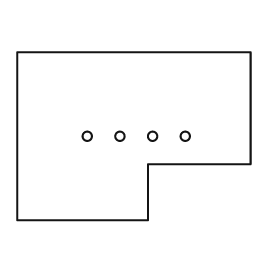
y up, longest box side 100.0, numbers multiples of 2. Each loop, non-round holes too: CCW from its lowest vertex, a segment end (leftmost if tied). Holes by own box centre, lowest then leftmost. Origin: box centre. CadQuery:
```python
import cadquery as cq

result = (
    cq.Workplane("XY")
    .moveTo(-50.0, -36.0)
    .lineTo(6.0, -36.0)
    .lineTo(6.0, -12.0)
    .lineTo(50.0, -12.0)
    .lineTo(50.0, 36.0)
    .lineTo(-50.0, 36.0)
    .close()
    .moveTo(-20.0, 0.0)
    .circle(2.0)
    .moveTo(-6.0, 0.0)
    .circle(2.0)
    .moveTo(8.0, 0.0)
    .circle(2.0)
    .moveTo(22.0, 0.0)
    .circle(2.0)
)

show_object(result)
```